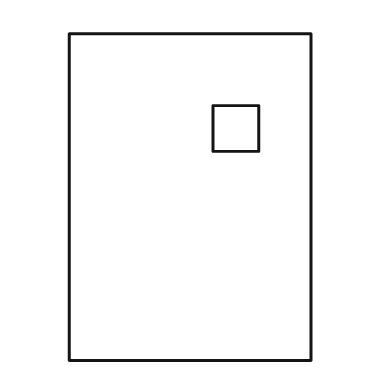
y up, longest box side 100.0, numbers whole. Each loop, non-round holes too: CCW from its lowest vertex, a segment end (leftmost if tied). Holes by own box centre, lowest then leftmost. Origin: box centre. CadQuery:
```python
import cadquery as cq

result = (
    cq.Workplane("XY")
    .moveTo(-37.0, -50.0)
    .lineTo(37.0, -50.0)
    .lineTo(37.0, 50.0)
    .lineTo(-37.0, 50.0)
    .close()
    .moveTo(7.0, 14.0)
    .lineTo(21.0, 14.0)
    .lineTo(21.0, 28.0)
    .lineTo(7.0, 28.0)
    .close()
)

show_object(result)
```